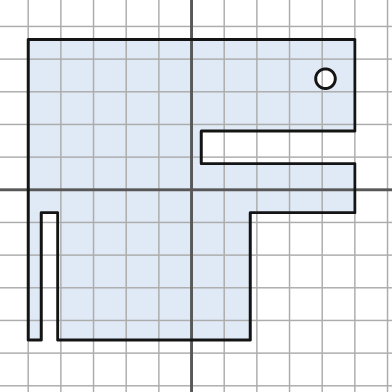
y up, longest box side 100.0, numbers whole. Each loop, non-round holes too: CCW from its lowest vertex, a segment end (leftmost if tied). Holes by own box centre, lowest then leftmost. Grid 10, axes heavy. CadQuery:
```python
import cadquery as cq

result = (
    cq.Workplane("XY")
    .moveTo(-50.0, -46.0)
    .lineTo(-46.0, -46.0)
    .lineTo(-46.0, -7.0)
    .lineTo(-41.0, -7.0)
    .lineTo(-41.0, -46.0)
    .lineTo(18.0, -46.0)
    .lineTo(18.0, -7.0)
    .lineTo(50.0, -7.0)
    .lineTo(50.0, 8.0)
    .lineTo(3.0, 8.0)
    .lineTo(3.0, 18.0)
    .lineTo(50.0, 18.0)
    .lineTo(50.0, 46.0)
    .lineTo(-50.0, 46.0)
    .close()
    .moveTo(41.0, 34.0)
    .circle(3.0)
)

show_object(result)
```